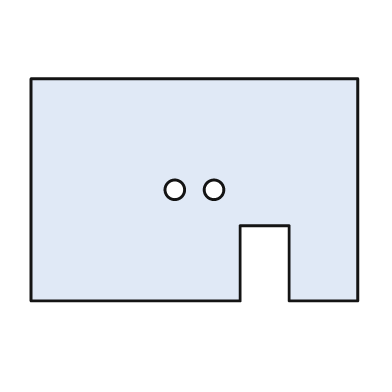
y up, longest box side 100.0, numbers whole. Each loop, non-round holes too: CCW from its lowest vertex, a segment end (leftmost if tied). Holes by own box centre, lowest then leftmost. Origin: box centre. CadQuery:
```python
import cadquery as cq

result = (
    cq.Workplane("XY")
    .moveTo(-50.0, -34.0)
    .lineTo(14.0, -34.0)
    .lineTo(14.0, -11.0)
    .lineTo(29.0, -11.0)
    .lineTo(29.0, -34.0)
    .lineTo(50.0, -34.0)
    .lineTo(50.0, 34.0)
    .lineTo(-50.0, 34.0)
    .close()
    .moveTo(-6.0, 0.0)
    .circle(3.0)
    .moveTo(6.0, 0.0)
    .circle(3.0)
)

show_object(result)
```